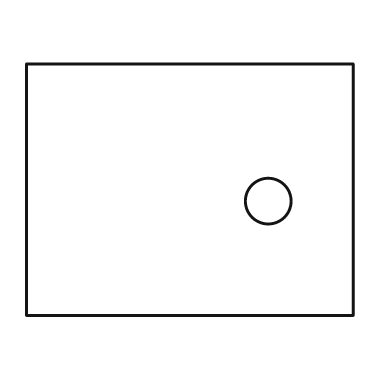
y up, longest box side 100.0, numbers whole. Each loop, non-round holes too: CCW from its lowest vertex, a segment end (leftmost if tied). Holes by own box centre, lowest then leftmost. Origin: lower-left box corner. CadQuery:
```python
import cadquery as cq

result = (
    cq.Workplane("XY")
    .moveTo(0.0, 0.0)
    .lineTo(100.0, 0.0)
    .lineTo(100.0, 77.0)
    .lineTo(0.0, 77.0)
    .close()
    .moveTo(74.0, 35.0)
    .circle(7.0)
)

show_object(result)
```